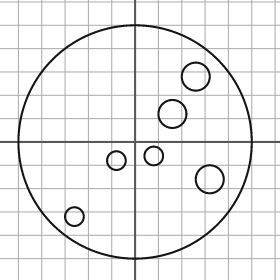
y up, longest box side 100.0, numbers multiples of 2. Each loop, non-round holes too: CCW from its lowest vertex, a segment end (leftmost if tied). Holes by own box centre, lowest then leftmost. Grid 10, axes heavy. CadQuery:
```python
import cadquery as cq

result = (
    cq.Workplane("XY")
    .moveTo(0.0, 0.0)
    .circle(50.0)
    .moveTo(-26.0, -32.0)
    .circle(4.0)
    .moveTo(32.0, -16.0)
    .circle(6.0)
    .moveTo(-8.0, -8.0)
    .circle(4.0)
    .moveTo(8.0, -6.0)
    .circle(4.0)
    .moveTo(16.0, 12.0)
    .circle(6.0)
    .moveTo(26.0, 28.0)
    .circle(6.0)
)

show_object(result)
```